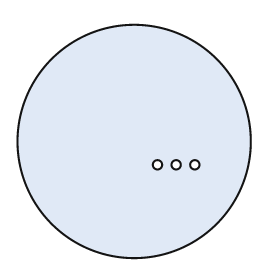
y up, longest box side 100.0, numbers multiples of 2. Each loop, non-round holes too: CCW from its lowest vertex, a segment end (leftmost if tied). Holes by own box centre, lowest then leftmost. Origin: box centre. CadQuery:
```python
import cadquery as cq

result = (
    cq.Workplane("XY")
    .moveTo(0.0, 0.0)
    .circle(50.0)
    .moveTo(10.0, -10.0)
    .circle(2.0)
    .moveTo(18.0, -10.0)
    .circle(2.0)
    .moveTo(26.0, -10.0)
    .circle(2.0)
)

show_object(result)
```